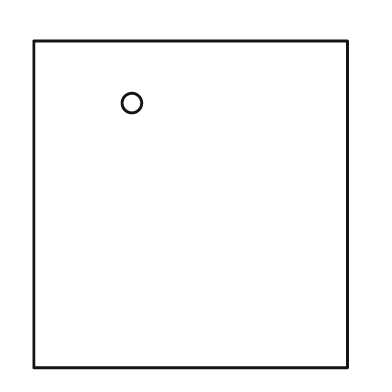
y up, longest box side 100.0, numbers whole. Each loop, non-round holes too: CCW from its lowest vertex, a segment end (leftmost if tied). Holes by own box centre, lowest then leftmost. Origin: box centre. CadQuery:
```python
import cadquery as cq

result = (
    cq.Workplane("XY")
    .moveTo(-48.0, -50.0)
    .lineTo(48.0, -50.0)
    .lineTo(48.0, 50.0)
    .lineTo(-48.0, 50.0)
    .close()
    .moveTo(-18.0, 31.0)
    .circle(3.0)
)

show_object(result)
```